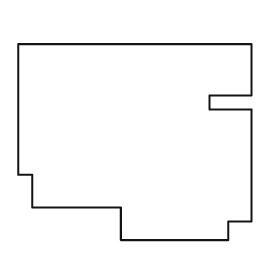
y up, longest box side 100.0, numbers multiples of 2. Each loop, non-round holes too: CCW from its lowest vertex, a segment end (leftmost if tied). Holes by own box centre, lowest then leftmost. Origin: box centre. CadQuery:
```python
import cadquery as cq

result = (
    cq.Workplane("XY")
    .moveTo(-6.0, -42.0)
    .lineTo(40.0, -42.0)
    .lineTo(40.0, -34.0)
    .lineTo(50.0, -34.0)
    .lineTo(50.0, 14.0)
    .lineTo(32.0, 14.0)
    .lineTo(32.0, 20.0)
    .lineTo(50.0, 20.0)
    .lineTo(50.0, 42.0)
    .lineTo(-50.0, 42.0)
    .lineTo(-50.0, -14.0)
    .lineTo(-44.0, -14.0)
    .lineTo(-44.0, -28.0)
    .lineTo(-6.0, -28.0)
    .close()
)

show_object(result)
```